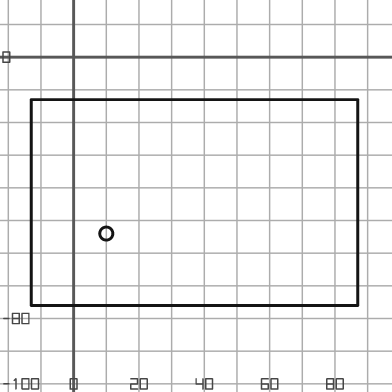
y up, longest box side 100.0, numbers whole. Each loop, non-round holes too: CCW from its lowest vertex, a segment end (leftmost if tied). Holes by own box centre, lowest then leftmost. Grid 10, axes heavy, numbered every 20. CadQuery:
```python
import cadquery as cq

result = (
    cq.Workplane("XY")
    .moveTo(-13.0, -76.0)
    .lineTo(87.0, -76.0)
    .lineTo(87.0, -13.0)
    .lineTo(-13.0, -13.0)
    .close()
    .moveTo(10.0, -54.0)
    .circle(2.0)
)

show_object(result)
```